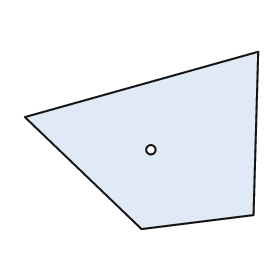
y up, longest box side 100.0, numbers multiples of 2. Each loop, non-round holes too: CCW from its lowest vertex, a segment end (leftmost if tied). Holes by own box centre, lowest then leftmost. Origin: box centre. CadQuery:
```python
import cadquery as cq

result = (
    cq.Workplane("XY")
    .moveTo(0.0, -38.0)
    .lineTo(48.0, -32.0)
    .lineTo(50.0, 38.0)
    .lineTo(-50.0, 10.0)
    .close()
    .moveTo(4.0, -4.0)
    .circle(2.0)
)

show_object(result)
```